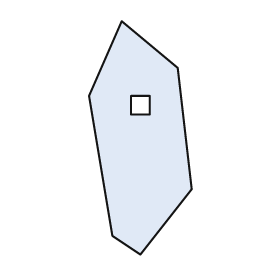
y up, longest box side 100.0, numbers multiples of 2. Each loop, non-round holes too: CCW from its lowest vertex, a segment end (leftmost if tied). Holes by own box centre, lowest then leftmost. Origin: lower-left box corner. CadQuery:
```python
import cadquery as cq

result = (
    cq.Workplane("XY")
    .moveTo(22.0, 0.0)
    .lineTo(44.0, 28.0)
    .lineTo(38.0, 80.0)
    .lineTo(14.0, 100.0)
    .lineTo(0.0, 68.0)
    .lineTo(10.0, 8.0)
    .close()
    .moveTo(18.0, 60.0)
    .lineTo(26.0, 60.0)
    .lineTo(26.0, 68.0)
    .lineTo(18.0, 68.0)
    .close()
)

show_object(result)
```